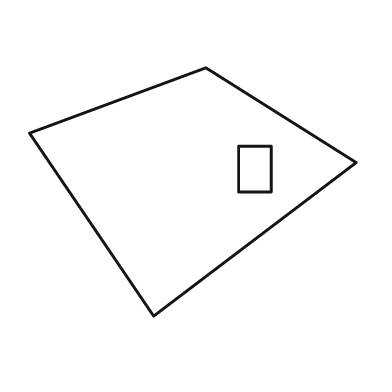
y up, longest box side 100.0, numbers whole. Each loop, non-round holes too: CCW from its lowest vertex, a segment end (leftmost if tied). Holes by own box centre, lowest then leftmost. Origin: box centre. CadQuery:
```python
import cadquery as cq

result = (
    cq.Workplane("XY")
    .moveTo(-12.0, -38.0)
    .lineTo(50.0, 9.0)
    .lineTo(4.0, 38.0)
    .lineTo(-50.0, 18.0)
    .close()
    .moveTo(14.0, 0.0)
    .lineTo(24.0, 0.0)
    .lineTo(24.0, 14.0)
    .lineTo(14.0, 14.0)
    .close()
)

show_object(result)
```